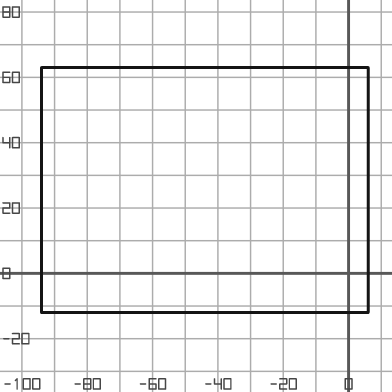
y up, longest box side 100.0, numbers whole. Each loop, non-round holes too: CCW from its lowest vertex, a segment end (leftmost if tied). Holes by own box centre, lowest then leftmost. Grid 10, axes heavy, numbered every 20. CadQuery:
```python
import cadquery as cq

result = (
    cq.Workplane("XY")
    .moveTo(-94.0, -12.0)
    .lineTo(6.0, -12.0)
    .lineTo(6.0, 63.0)
    .lineTo(-94.0, 63.0)
    .close()
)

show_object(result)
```